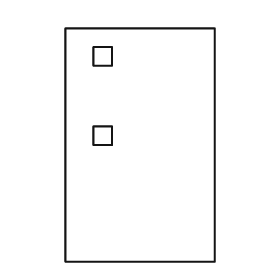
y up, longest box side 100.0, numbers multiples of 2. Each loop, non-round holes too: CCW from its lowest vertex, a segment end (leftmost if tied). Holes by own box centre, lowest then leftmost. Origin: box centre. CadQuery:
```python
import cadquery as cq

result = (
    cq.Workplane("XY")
    .moveTo(-32.0, -50.0)
    .lineTo(32.0, -50.0)
    .lineTo(32.0, 50.0)
    .lineTo(-32.0, 50.0)
    .close()
    .moveTo(-20.0, 0.0)
    .lineTo(-12.0, 0.0)
    .lineTo(-12.0, 8.0)
    .lineTo(-20.0, 8.0)
    .close()
    .moveTo(-20.0, 34.0)
    .lineTo(-12.0, 34.0)
    .lineTo(-12.0, 42.0)
    .lineTo(-20.0, 42.0)
    .close()
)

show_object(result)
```